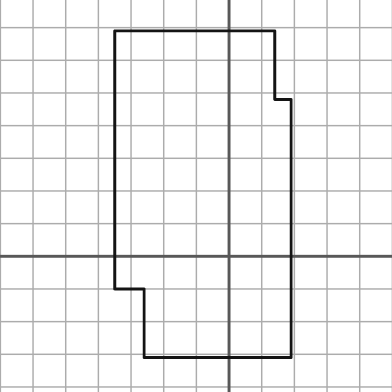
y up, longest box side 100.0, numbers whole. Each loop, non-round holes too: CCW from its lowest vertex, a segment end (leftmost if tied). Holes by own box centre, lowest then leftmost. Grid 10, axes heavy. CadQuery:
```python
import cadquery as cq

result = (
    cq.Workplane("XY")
    .moveTo(-26.0, -31.0)
    .lineTo(19.0, -31.0)
    .lineTo(19.0, 48.0)
    .lineTo(14.0, 48.0)
    .lineTo(14.0, 69.0)
    .lineTo(-35.0, 69.0)
    .lineTo(-35.0, -10.0)
    .lineTo(-26.0, -10.0)
    .close()
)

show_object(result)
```